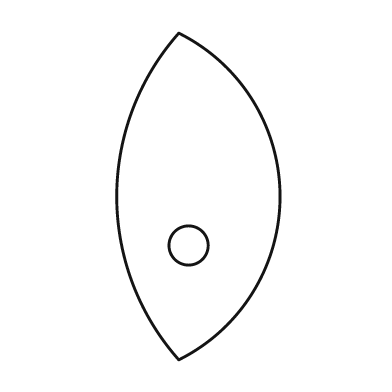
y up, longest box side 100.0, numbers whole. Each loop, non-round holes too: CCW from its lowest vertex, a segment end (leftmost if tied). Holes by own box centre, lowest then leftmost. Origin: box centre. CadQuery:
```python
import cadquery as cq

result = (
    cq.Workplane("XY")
    .moveTo(-6.0, -50.0)
    .threePointArc((25.0, 0.0), (-6.0, 50.0))
    .threePointArc((-25.0, 0.0), (-6.0, -50.0))
    .close()
    .moveTo(-3.0, -15.0)
    .circle(6.0)
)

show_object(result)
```